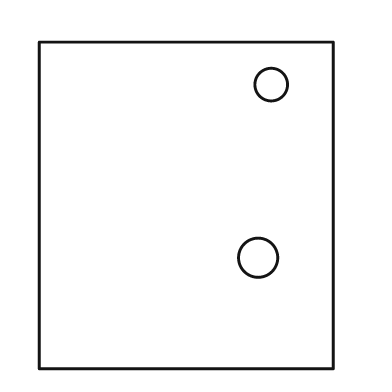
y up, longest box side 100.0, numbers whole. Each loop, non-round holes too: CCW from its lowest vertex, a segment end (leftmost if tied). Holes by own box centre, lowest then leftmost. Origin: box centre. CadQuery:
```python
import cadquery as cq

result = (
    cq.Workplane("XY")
    .moveTo(-45.0, -50.0)
    .lineTo(45.0, -50.0)
    .lineTo(45.0, 50.0)
    .lineTo(-45.0, 50.0)
    .close()
    .moveTo(22.0, -16.0)
    .circle(6.0)
    .moveTo(26.0, 37.0)
    .circle(5.0)
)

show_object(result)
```